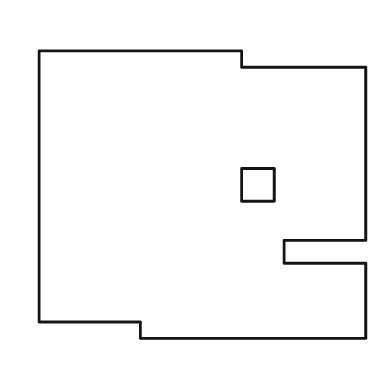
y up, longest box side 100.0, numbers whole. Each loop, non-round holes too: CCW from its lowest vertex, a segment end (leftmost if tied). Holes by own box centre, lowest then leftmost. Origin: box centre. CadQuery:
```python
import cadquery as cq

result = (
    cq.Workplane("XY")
    .moveTo(-19.0, -44.0)
    .lineTo(50.0, -44.0)
    .lineTo(50.0, -21.0)
    .lineTo(25.0, -21.0)
    .lineTo(25.0, -14.0)
    .lineTo(50.0, -14.0)
    .lineTo(50.0, 39.0)
    .lineTo(12.0, 39.0)
    .lineTo(12.0, 44.0)
    .lineTo(-50.0, 44.0)
    .lineTo(-50.0, -39.0)
    .lineTo(-19.0, -39.0)
    .close()
    .moveTo(12.0, -2.0)
    .lineTo(22.0, -2.0)
    .lineTo(22.0, 8.0)
    .lineTo(12.0, 8.0)
    .close()
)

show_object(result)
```